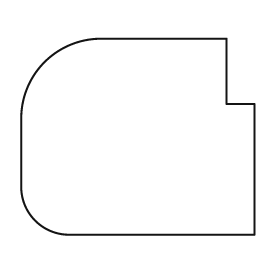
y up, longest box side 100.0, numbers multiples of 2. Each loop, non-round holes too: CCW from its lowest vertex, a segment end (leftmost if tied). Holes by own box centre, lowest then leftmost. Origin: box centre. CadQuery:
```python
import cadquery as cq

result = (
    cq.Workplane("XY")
    .moveTo(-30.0, -42.0)
    .lineTo(50.0, -42.0)
    .lineTo(50.0, 14.0)
    .lineTo(38.0, 14.0)
    .lineTo(38.0, 42.0)
    .lineTo(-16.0, 42.0)
    .threePointArc((-40.0, 32.0), (-50.0, 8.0))
    .lineTo(-50.0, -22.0)
    .threePointArc((-44.0, -36.0), (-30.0, -42.0))
    .close()
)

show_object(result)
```